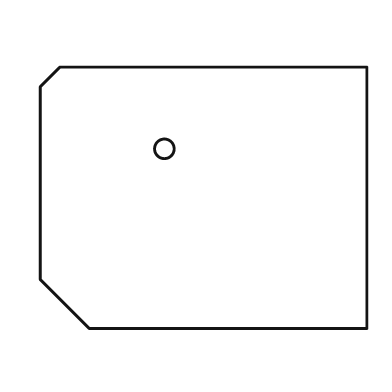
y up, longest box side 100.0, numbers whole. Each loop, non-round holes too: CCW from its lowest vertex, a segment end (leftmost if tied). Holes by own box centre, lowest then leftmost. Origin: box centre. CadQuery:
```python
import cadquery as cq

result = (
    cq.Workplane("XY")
    .moveTo(-35.0, -40.0)
    .lineTo(50.0, -40.0)
    .lineTo(50.0, 40.0)
    .lineTo(-44.0, 40.0)
    .lineTo(-50.0, 34.0)
    .lineTo(-50.0, -25.0)
    .close()
    .moveTo(-12.0, 15.0)
    .circle(3.0)
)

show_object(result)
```